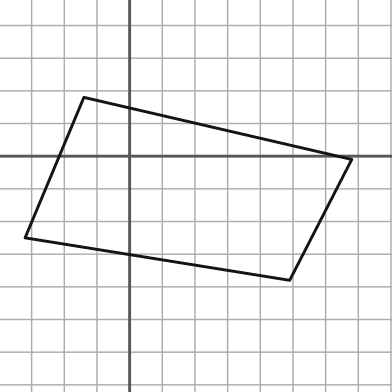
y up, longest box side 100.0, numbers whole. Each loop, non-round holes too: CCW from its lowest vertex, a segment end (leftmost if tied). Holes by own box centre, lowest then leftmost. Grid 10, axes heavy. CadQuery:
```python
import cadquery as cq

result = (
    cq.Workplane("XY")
    .moveTo(49.0, -38.0)
    .lineTo(68.0, -1.0)
    .lineTo(-14.0, 18.0)
    .lineTo(-32.0, -25.0)
    .close()
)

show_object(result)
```